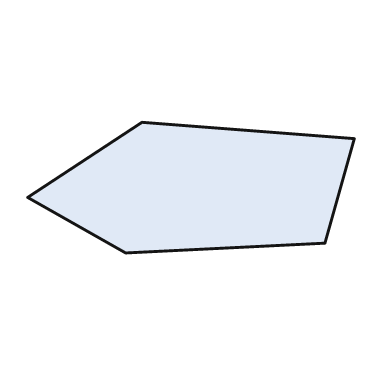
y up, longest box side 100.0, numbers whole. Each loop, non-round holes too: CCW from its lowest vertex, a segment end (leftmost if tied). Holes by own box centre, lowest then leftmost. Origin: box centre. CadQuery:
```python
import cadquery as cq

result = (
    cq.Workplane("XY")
    .moveTo(-20.0, -20.0)
    .lineTo(41.0, -17.0)
    .lineTo(50.0, 15.0)
    .lineTo(-15.0, 20.0)
    .lineTo(-50.0, -3.0)
    .close()
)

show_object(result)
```